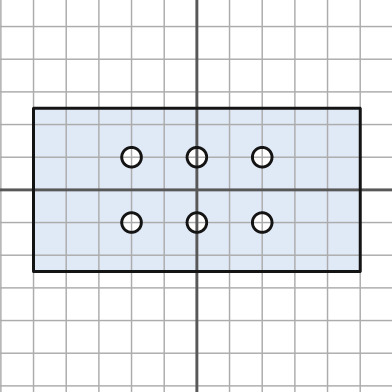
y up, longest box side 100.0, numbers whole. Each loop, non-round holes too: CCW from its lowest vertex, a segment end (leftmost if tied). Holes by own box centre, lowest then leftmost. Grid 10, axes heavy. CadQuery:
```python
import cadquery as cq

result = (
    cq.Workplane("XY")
    .moveTo(-50.0, -25.0)
    .lineTo(50.0, -25.0)
    .lineTo(50.0, 25.0)
    .lineTo(-50.0, 25.0)
    .close()
    .moveTo(-20.0, -10.0)
    .circle(3.0)
    .moveTo(0.0, -10.0)
    .circle(3.0)
    .moveTo(20.0, -10.0)
    .circle(3.0)
    .moveTo(-20.0, 10.0)
    .circle(3.0)
    .moveTo(0.0, 10.0)
    .circle(3.0)
    .moveTo(20.0, 10.0)
    .circle(3.0)
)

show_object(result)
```